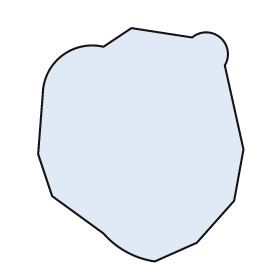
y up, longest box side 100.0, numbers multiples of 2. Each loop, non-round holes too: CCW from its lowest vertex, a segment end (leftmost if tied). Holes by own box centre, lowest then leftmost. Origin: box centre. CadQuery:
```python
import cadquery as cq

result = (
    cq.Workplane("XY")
    .moveTo(6.0, -50.0)
    .lineTo(24.0, -42.0)
    .lineTo(40.0, -24.0)
    .lineTo(44.0, -2.0)
    .lineTo(36.0, 34.0)
    .threePointArc((34.0, 46.0), (22.0, 46.0))
    .lineTo(-4.0, 50.0)
    .lineTo(-16.0, 42.0)
    .threePointArc((-34.0, 38.0), (-42.0, 22.0))
    .lineTo(-44.0, -4.0)
    .lineTo(-38.0, -22.0)
    .lineTo(-16.0, -38.0)
    .threePointArc((-6.0, -46.0), (6.0, -50.0))
    .close()
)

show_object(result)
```